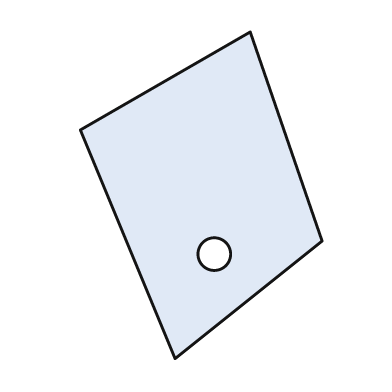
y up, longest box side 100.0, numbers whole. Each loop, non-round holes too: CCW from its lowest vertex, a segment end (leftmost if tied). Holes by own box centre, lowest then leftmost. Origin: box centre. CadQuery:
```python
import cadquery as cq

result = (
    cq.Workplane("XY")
    .moveTo(-8.0, -50.0)
    .lineTo(37.0, -14.0)
    .lineTo(15.0, 50.0)
    .lineTo(-37.0, 20.0)
    .close()
    .moveTo(4.0, -18.0)
    .circle(5.0)
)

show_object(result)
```